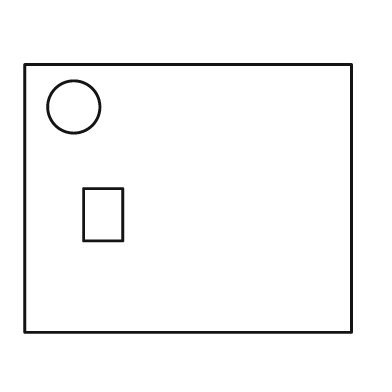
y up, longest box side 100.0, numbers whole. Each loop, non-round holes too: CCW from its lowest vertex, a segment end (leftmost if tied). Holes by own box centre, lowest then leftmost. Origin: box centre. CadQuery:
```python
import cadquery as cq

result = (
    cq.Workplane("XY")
    .moveTo(-50.0, -41.0)
    .lineTo(50.0, -41.0)
    .lineTo(50.0, 41.0)
    .lineTo(-50.0, 41.0)
    .close()
    .moveTo(-32.0, -13.0)
    .lineTo(-20.0, -13.0)
    .lineTo(-20.0, 3.0)
    .lineTo(-32.0, 3.0)
    .close()
    .moveTo(-35.0, 28.0)
    .circle(8.0)
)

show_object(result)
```